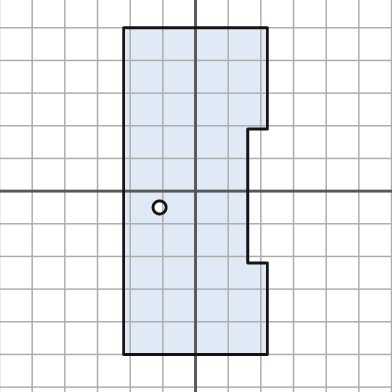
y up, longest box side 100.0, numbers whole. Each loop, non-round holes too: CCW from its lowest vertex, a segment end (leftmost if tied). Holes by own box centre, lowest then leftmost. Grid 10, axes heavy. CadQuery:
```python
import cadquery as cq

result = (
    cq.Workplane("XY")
    .moveTo(-22.0, -50.0)
    .lineTo(22.0, -50.0)
    .lineTo(22.0, -22.0)
    .lineTo(16.0, -22.0)
    .lineTo(16.0, 19.0)
    .lineTo(22.0, 19.0)
    .lineTo(22.0, 50.0)
    .lineTo(-22.0, 50.0)
    .close()
    .moveTo(-11.0, -5.0)
    .circle(2.0)
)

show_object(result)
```